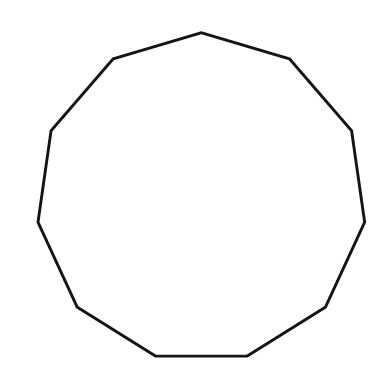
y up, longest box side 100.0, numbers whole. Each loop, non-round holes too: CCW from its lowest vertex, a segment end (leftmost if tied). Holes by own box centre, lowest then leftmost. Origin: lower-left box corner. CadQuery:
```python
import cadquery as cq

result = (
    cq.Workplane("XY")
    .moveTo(36.0, 0.0)
    .lineTo(64.0, 0.0)
    .lineTo(88.0, 15.0)
    .lineTo(100.0, 41.0)
    .lineTo(96.0, 69.0)
    .lineTo(77.0, 91.0)
    .lineTo(50.0, 99.0)
    .lineTo(23.0, 91.0)
    .lineTo(4.0, 69.0)
    .lineTo(0.0, 41.0)
    .lineTo(12.0, 15.0)
    .close()
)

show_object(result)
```